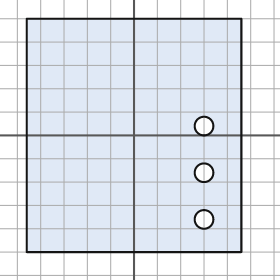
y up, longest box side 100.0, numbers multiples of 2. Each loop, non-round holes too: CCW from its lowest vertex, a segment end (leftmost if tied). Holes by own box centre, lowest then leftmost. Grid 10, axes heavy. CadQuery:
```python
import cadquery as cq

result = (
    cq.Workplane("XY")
    .moveTo(-46.0, -50.0)
    .lineTo(46.0, -50.0)
    .lineTo(46.0, 50.0)
    .lineTo(-46.0, 50.0)
    .close()
    .moveTo(30.0, -36.0)
    .circle(4.0)
    .moveTo(30.0, -16.0)
    .circle(4.0)
    .moveTo(30.0, 4.0)
    .circle(4.0)
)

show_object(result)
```